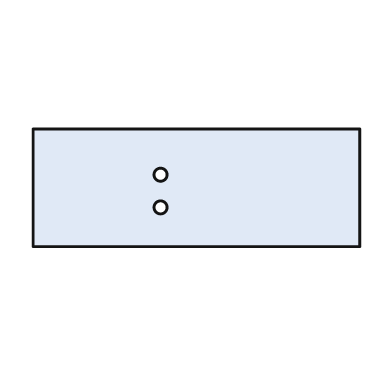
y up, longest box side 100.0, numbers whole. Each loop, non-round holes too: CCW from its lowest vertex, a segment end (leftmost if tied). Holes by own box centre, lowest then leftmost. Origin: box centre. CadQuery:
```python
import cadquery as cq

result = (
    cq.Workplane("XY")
    .moveTo(-50.0, -18.0)
    .lineTo(50.0, -18.0)
    .lineTo(50.0, 18.0)
    .lineTo(-50.0, 18.0)
    .close()
    .moveTo(-11.0, -6.0)
    .circle(2.0)
    .moveTo(-11.0, 4.0)
    .circle(2.0)
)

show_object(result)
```